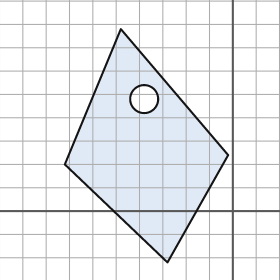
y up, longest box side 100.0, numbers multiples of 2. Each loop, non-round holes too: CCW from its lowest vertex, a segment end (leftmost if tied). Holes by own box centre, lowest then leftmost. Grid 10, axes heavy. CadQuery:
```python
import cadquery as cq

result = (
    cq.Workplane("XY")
    .moveTo(-28.0, -22.0)
    .lineTo(-2.0, 24.0)
    .lineTo(-48.0, 78.0)
    .lineTo(-72.0, 20.0)
    .close()
    .moveTo(-38.0, 48.0)
    .circle(6.0)
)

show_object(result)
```